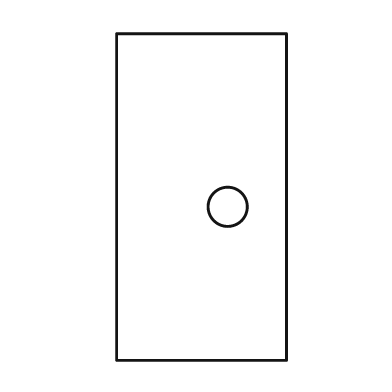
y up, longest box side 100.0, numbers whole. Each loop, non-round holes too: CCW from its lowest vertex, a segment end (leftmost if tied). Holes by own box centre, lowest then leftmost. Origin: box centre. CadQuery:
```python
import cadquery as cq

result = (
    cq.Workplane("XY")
    .moveTo(-26.0, -50.0)
    .lineTo(26.0, -50.0)
    .lineTo(26.0, 50.0)
    .lineTo(-26.0, 50.0)
    .close()
    .moveTo(8.0, -3.0)
    .circle(6.0)
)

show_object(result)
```